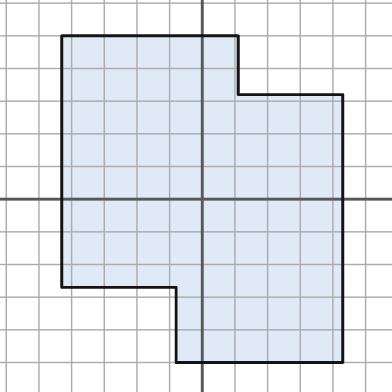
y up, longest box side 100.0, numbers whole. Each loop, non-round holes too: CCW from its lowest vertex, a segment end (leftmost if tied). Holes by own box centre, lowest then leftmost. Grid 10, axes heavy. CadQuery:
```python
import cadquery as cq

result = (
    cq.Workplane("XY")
    .moveTo(-8.0, -50.0)
    .lineTo(43.0, -50.0)
    .lineTo(43.0, 32.0)
    .lineTo(11.0, 32.0)
    .lineTo(11.0, 50.0)
    .lineTo(-43.0, 50.0)
    .lineTo(-43.0, -27.0)
    .lineTo(-8.0, -27.0)
    .close()
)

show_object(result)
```